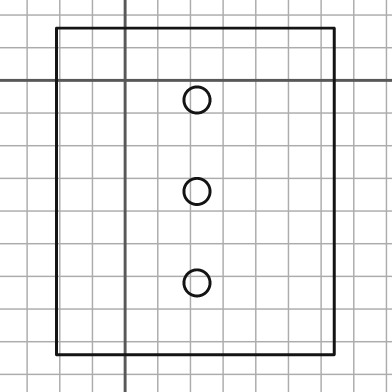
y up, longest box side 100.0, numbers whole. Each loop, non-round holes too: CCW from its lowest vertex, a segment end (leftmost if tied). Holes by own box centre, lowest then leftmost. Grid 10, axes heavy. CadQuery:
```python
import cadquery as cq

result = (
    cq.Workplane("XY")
    .moveTo(-21.0, -84.0)
    .lineTo(64.0, -84.0)
    .lineTo(64.0, 16.0)
    .lineTo(-21.0, 16.0)
    .close()
    .moveTo(22.0, -62.0)
    .circle(4.0)
    .moveTo(22.0, -34.0)
    .circle(4.0)
    .moveTo(22.0, -6.0)
    .circle(4.0)
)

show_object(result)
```